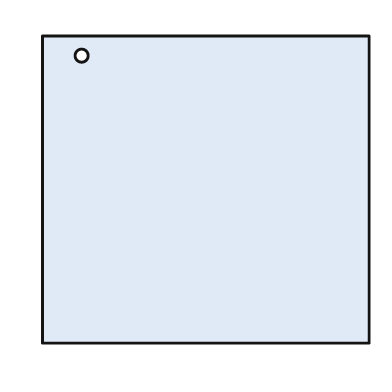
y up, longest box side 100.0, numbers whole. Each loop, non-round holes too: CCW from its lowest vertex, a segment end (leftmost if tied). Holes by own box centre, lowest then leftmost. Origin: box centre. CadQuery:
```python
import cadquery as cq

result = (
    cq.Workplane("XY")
    .moveTo(-50.0, -47.0)
    .lineTo(50.0, -47.0)
    .lineTo(50.0, 47.0)
    .lineTo(-50.0, 47.0)
    .close()
    .moveTo(-38.0, 41.0)
    .circle(2.0)
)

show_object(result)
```